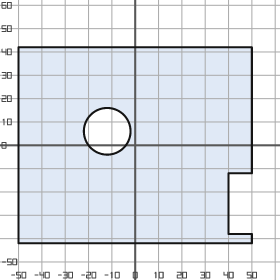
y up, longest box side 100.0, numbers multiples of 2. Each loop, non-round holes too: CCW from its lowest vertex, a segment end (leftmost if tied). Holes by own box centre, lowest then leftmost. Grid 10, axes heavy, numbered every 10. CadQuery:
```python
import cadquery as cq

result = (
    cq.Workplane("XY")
    .moveTo(-50.0, -42.0)
    .lineTo(50.0, -42.0)
    .lineTo(50.0, -38.0)
    .lineTo(40.0, -38.0)
    .lineTo(40.0, -12.0)
    .lineTo(50.0, -12.0)
    .lineTo(50.0, 42.0)
    .lineTo(-50.0, 42.0)
    .close()
    .moveTo(-12.0, 6.0)
    .circle(10.0)
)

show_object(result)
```